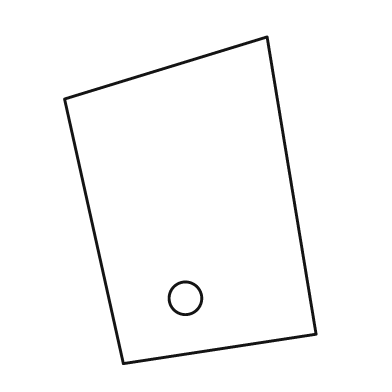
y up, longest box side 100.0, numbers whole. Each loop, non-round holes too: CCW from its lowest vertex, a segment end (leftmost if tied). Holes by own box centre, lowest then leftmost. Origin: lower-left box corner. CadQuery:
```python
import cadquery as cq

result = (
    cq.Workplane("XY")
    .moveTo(18.0, 0.0)
    .lineTo(77.0, 9.0)
    .lineTo(62.0, 100.0)
    .lineTo(0.0, 81.0)
    .close()
    .moveTo(37.0, 20.0)
    .circle(5.0)
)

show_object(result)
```